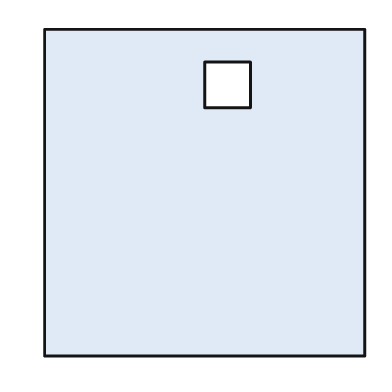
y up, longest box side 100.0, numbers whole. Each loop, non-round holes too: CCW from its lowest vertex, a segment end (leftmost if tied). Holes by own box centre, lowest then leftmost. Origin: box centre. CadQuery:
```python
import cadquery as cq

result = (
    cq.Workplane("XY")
    .moveTo(-49.0, -50.0)
    .lineTo(49.0, -50.0)
    .lineTo(49.0, 50.0)
    .lineTo(-49.0, 50.0)
    .close()
    .moveTo(0.0, 26.0)
    .lineTo(14.0, 26.0)
    .lineTo(14.0, 40.0)
    .lineTo(0.0, 40.0)
    .close()
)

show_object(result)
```